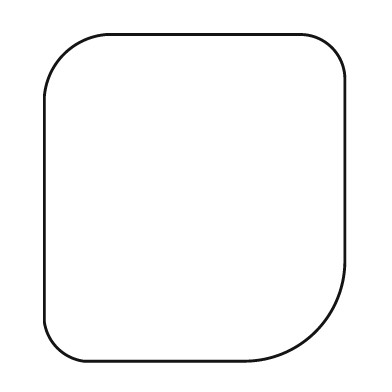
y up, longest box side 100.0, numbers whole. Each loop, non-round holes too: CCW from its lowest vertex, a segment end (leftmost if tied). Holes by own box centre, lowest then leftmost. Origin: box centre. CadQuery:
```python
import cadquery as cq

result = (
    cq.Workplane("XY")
    .moveTo(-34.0, -50.0)
    .lineTo(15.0, -50.0)
    .threePointArc((37.0, -41.0), (46.0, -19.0))
    .lineTo(46.0, 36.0)
    .threePointArc((42.0, 46.0), (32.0, 50.0))
    .lineTo(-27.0, 50.0)
    .threePointArc((-40.0, 44.0), (-46.0, 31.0))
    .lineTo(-46.0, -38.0)
    .threePointArc((-42.0, -46.0), (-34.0, -50.0))
    .close()
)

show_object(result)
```